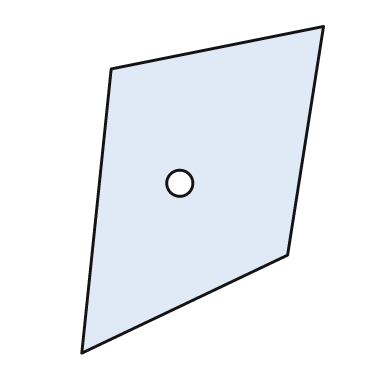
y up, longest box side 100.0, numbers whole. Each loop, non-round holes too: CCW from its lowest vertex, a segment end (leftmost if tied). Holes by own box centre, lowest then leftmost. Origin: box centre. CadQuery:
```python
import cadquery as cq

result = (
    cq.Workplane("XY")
    .moveTo(-37.0, -50.0)
    .lineTo(26.0, -20.0)
    .lineTo(37.0, 50.0)
    .lineTo(-28.0, 37.0)
    .close()
    .moveTo(-7.0, 2.0)
    .circle(4.0)
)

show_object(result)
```